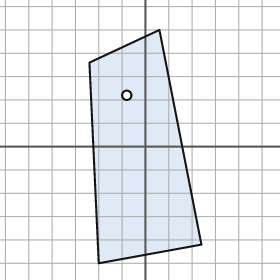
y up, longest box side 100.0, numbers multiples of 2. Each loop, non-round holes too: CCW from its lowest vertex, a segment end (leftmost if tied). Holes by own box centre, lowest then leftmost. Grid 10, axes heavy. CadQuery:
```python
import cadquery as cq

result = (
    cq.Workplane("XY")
    .moveTo(-20.0, -50.0)
    .lineTo(24.0, -42.0)
    .lineTo(6.0, 50.0)
    .lineTo(-24.0, 36.0)
    .close()
    .moveTo(-8.0, 22.0)
    .circle(2.0)
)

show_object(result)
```